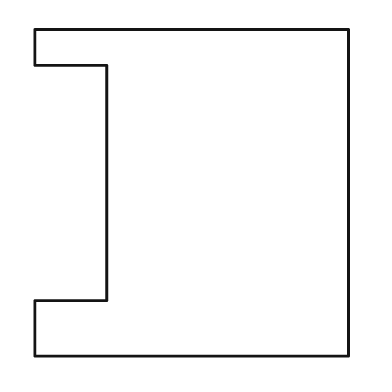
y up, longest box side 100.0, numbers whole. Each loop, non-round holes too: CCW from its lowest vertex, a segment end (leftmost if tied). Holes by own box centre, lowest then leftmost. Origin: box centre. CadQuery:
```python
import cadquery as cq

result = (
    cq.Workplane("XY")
    .moveTo(-48.0, -50.0)
    .lineTo(48.0, -50.0)
    .lineTo(48.0, 50.0)
    .lineTo(-48.0, 50.0)
    .lineTo(-48.0, 39.0)
    .lineTo(-26.0, 39.0)
    .lineTo(-26.0, -33.0)
    .lineTo(-48.0, -33.0)
    .close()
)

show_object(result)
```